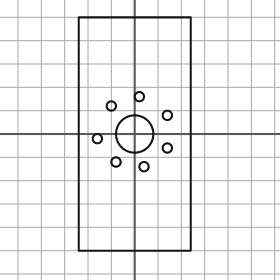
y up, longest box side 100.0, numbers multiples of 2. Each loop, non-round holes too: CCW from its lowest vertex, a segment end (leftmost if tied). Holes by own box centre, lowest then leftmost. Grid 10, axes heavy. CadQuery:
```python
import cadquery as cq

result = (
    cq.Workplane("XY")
    .moveTo(-24.0, -50.0)
    .lineTo(24.0, -50.0)
    .lineTo(24.0, 50.0)
    .lineTo(-24.0, 50.0)
    .close()
    .moveTo(4.0, -14.0)
    .circle(2.0)
    .moveTo(-8.0, -12.0)
    .circle(2.0)
    .moveTo(14.0, -6.0)
    .circle(2.0)
    .moveTo(-16.0, -2.0)
    .circle(2.0)
    .moveTo(0.0, 0.0)
    .circle(8.0)
    .moveTo(14.0, 8.0)
    .circle(2.0)
    .moveTo(-10.0, 12.0)
    .circle(2.0)
    .moveTo(2.0, 16.0)
    .circle(2.0)
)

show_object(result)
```